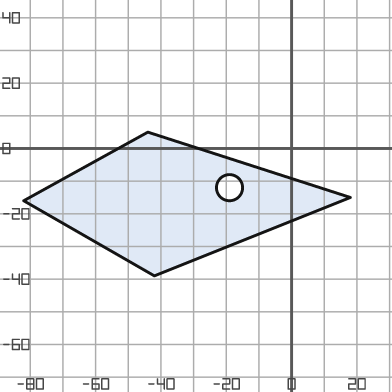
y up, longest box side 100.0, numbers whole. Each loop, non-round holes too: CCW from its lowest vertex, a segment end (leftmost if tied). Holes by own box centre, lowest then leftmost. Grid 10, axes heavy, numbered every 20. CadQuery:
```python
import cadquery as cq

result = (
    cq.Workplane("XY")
    .moveTo(-42.0, -39.0)
    .lineTo(18.0, -15.0)
    .lineTo(-44.0, 5.0)
    .lineTo(-82.0, -16.0)
    .close()
    .moveTo(-19.0, -12.0)
    .circle(4.0)
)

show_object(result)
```